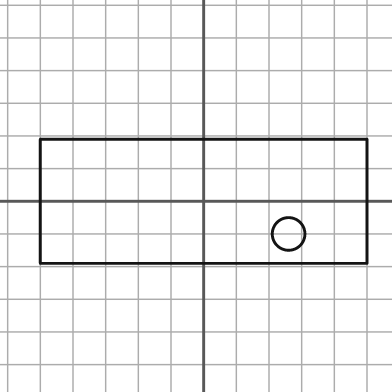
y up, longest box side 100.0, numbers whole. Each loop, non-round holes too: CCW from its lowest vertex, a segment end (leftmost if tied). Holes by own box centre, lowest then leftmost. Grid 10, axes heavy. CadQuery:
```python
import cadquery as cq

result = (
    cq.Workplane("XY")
    .moveTo(-50.0, -19.0)
    .lineTo(50.0, -19.0)
    .lineTo(50.0, 19.0)
    .lineTo(-50.0, 19.0)
    .close()
    .moveTo(26.0, -10.0)
    .circle(5.0)
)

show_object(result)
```